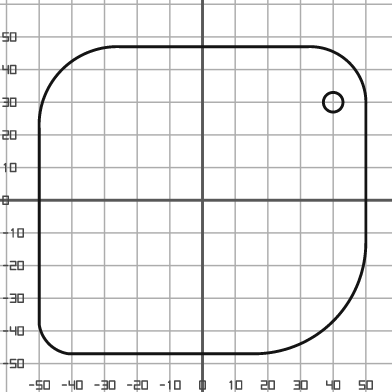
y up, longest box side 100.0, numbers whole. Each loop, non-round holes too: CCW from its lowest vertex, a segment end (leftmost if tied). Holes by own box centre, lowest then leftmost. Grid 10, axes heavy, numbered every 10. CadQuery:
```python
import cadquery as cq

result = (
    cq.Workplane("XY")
    .moveTo(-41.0, -47.0)
    .lineTo(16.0, -47.0)
    .threePointArc((40.0, -37.0), (50.0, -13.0))
    .lineTo(50.0, 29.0)
    .threePointArc((45.0, 42.0), (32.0, 47.0))
    .lineTo(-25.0, 47.0)
    .threePointArc((-43.0, 40.0), (-50.0, 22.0))
    .lineTo(-50.0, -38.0)
    .threePointArc((-47.0, -44.0), (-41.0, -47.0))
    .close()
    .moveTo(40.0, 30.0)
    .circle(3.0)
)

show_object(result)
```